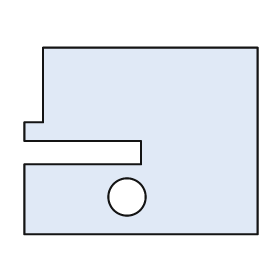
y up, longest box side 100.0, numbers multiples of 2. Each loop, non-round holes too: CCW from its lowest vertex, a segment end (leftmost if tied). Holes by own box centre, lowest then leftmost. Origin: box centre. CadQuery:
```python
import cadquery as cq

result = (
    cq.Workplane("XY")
    .moveTo(-50.0, -40.0)
    .lineTo(50.0, -40.0)
    .lineTo(50.0, 40.0)
    .lineTo(-42.0, 40.0)
    .lineTo(-42.0, 8.0)
    .lineTo(-50.0, 8.0)
    .lineTo(-50.0, 0.0)
    .lineTo(0.0, 0.0)
    .lineTo(0.0, -10.0)
    .lineTo(-50.0, -10.0)
    .close()
    .moveTo(-6.0, -24.0)
    .circle(8.0)
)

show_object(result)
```